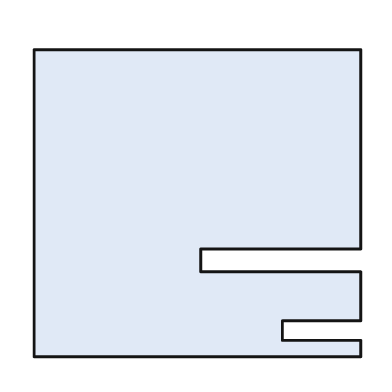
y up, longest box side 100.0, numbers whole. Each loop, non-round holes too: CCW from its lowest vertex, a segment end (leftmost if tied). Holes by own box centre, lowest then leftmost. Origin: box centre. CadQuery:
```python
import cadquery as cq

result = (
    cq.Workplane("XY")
    .moveTo(-50.0, -47.0)
    .lineTo(50.0, -47.0)
    .lineTo(50.0, -42.0)
    .lineTo(26.0, -42.0)
    .lineTo(26.0, -36.0)
    .lineTo(50.0, -36.0)
    .lineTo(50.0, -21.0)
    .lineTo(1.0, -21.0)
    .lineTo(1.0, -14.0)
    .lineTo(50.0, -14.0)
    .lineTo(50.0, 47.0)
    .lineTo(-50.0, 47.0)
    .close()
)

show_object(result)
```